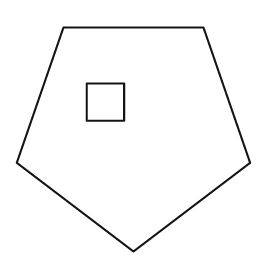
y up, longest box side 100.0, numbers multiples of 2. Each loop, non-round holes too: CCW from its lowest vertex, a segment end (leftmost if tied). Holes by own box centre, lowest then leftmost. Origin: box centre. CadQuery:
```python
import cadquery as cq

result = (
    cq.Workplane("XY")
    .moveTo(0.0, -48.0)
    .lineTo(50.0, -10.0)
    .lineTo(30.0, 48.0)
    .lineTo(-30.0, 48.0)
    .lineTo(-50.0, -10.0)
    .close()
    .moveTo(-20.0, 8.0)
    .lineTo(-4.0, 8.0)
    .lineTo(-4.0, 24.0)
    .lineTo(-20.0, 24.0)
    .close()
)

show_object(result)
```